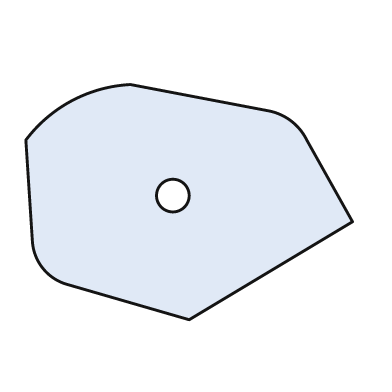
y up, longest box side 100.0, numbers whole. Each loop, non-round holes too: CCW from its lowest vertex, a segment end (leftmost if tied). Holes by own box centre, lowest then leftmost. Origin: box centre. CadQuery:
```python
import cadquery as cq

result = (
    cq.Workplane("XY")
    .moveTo(0.0, -36.0)
    .lineTo(50.0, -6.0)
    .lineTo(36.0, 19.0)
    .threePointArc((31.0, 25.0), (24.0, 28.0))
    .lineTo(-18.0, 36.0)
    .threePointArc((-36.0, 31.0), (-50.0, 19.0))
    .lineTo(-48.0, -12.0)
    .threePointArc((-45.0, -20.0), (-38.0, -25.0))
    .close()
    .moveTo(-5.0, 2.0)
    .circle(5.0)
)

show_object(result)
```